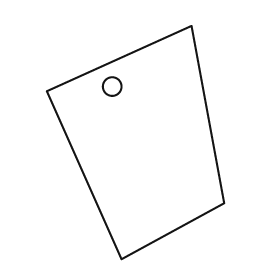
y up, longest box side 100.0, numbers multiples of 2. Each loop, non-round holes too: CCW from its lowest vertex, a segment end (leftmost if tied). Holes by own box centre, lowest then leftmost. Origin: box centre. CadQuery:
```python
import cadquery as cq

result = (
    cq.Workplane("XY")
    .moveTo(-6.0, -50.0)
    .lineTo(38.0, -26.0)
    .lineTo(24.0, 50.0)
    .lineTo(-38.0, 22.0)
    .close()
    .moveTo(-10.0, 24.0)
    .circle(4.0)
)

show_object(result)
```